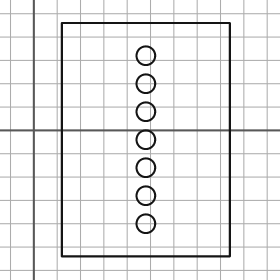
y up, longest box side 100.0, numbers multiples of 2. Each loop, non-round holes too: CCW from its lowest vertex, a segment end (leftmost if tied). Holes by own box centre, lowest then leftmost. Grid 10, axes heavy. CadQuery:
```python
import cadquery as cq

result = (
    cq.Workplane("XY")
    .moveTo(12.0, -54.0)
    .lineTo(84.0, -54.0)
    .lineTo(84.0, 46.0)
    .lineTo(12.0, 46.0)
    .close()
    .moveTo(48.0, -40.0)
    .circle(4.0)
    .moveTo(48.0, -28.0)
    .circle(4.0)
    .moveTo(48.0, -16.0)
    .circle(4.0)
    .moveTo(48.0, -4.0)
    .circle(4.0)
    .moveTo(48.0, 8.0)
    .circle(4.0)
    .moveTo(48.0, 20.0)
    .circle(4.0)
    .moveTo(48.0, 32.0)
    .circle(4.0)
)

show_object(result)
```